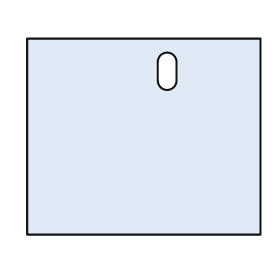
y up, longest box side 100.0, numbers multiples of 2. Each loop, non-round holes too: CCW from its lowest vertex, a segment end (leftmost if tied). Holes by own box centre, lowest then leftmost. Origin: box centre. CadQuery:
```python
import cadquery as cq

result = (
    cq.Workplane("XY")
    .moveTo(-50.0, -42.0)
    .lineTo(50.0, -42.0)
    .lineTo(50.0, 42.0)
    .lineTo(-50.0, 42.0)
    .close()
    .moveTo(6.0, 24.0)
    .threePointArc((10.0, 20.0), (14.0, 24.0))
    .lineTo(14.0, 32.0)
    .threePointArc((10.0, 36.0), (6.0, 32.0))
    .close()
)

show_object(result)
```